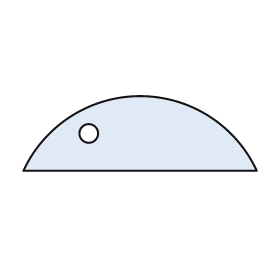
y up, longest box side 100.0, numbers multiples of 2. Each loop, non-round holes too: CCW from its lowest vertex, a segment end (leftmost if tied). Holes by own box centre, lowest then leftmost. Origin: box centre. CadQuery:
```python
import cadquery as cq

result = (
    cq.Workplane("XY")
    .moveTo(-50.0, -16.0)
    .lineTo(50.0, -16.0)
    .threePointArc((0.0, 16.0), (-50.0, -16.0))
    .close()
    .moveTo(-22.0, 0.0)
    .circle(4.0)
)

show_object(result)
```